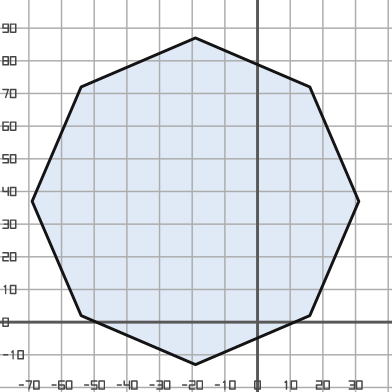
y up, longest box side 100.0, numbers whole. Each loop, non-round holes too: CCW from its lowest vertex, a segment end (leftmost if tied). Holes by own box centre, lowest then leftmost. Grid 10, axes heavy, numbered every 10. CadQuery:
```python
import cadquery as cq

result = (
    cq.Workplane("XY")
    .moveTo(-19.0, -13.0)
    .lineTo(16.0, 2.0)
    .lineTo(31.0, 37.0)
    .lineTo(16.0, 72.0)
    .lineTo(-19.0, 87.0)
    .lineTo(-54.0, 72.0)
    .lineTo(-69.0, 37.0)
    .lineTo(-54.0, 2.0)
    .close()
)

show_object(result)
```